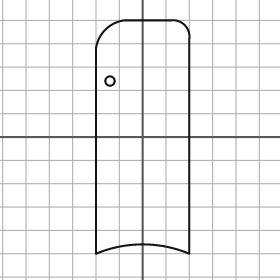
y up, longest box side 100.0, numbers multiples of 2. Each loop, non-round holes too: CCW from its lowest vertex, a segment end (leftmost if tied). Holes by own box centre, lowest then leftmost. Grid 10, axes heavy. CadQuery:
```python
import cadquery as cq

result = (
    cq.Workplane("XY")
    .moveTo(-20.0, -50.0)
    .threePointArc((0.0, -46.0), (20.0, -50.0))
    .lineTo(20.0, 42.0)
    .threePointArc((18.0, 48.0), (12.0, 50.0))
    .lineTo(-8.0, 50.0)
    .threePointArc((-16.0, 46.0), (-20.0, 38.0))
    .close()
    .moveTo(-14.0, 24.0)
    .circle(2.0)
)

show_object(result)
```